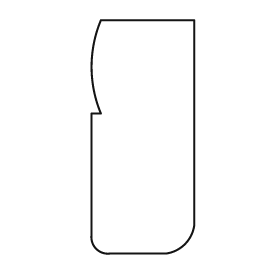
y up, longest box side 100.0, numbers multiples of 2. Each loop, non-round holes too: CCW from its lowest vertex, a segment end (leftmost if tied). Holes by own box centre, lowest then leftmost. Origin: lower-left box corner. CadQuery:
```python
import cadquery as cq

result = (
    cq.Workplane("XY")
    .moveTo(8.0, 0.0)
    .lineTo(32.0, 0.0)
    .threePointArc((40.0, 4.0), (44.0, 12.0))
    .lineTo(44.0, 100.0)
    .lineTo(4.0, 100.0)
    .threePointArc((0.0, 80.0), (4.0, 60.0))
    .lineTo(0.0, 60.0)
    .lineTo(0.0, 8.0)
    .threePointArc((2.0, 2.0), (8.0, 0.0))
    .close()
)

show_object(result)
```